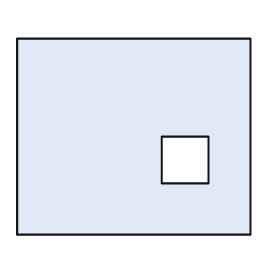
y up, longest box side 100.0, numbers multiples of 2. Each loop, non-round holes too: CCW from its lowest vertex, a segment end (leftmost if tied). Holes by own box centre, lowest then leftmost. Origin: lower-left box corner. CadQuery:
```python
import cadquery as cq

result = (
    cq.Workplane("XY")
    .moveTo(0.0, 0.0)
    .lineTo(100.0, 0.0)
    .lineTo(100.0, 84.0)
    .lineTo(0.0, 84.0)
    .close()
    .moveTo(62.0, 22.0)
    .lineTo(82.0, 22.0)
    .lineTo(82.0, 42.0)
    .lineTo(62.0, 42.0)
    .close()
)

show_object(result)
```